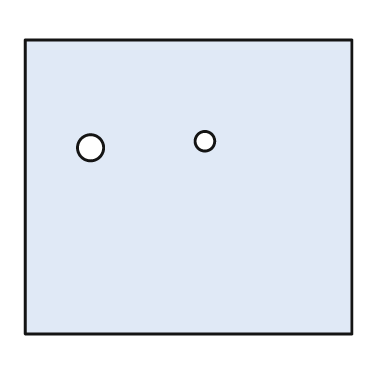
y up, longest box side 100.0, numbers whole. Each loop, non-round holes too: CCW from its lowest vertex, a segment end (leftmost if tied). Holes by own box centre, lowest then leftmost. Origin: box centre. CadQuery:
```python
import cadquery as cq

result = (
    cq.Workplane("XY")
    .moveTo(-50.0, -45.0)
    .lineTo(50.0, -45.0)
    .lineTo(50.0, 45.0)
    .lineTo(-50.0, 45.0)
    .close()
    .moveTo(-30.0, 12.0)
    .circle(4.0)
    .moveTo(5.0, 14.0)
    .circle(3.0)
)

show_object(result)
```